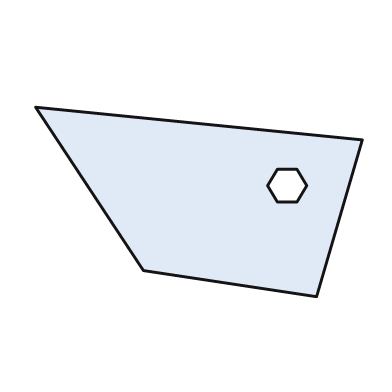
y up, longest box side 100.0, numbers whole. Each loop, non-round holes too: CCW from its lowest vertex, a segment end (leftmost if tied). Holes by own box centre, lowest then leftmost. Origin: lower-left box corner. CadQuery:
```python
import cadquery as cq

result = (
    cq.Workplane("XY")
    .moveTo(86.0, 0.0)
    .lineTo(100.0, 48.0)
    .lineTo(0.0, 58.0)
    .lineTo(33.0, 8.0)
    .close()
    .moveTo(74.0, 29.0)
    .lineTo(80.0, 29.0)
    .lineTo(83.0, 34.0)
    .lineTo(80.0, 39.0)
    .lineTo(74.0, 39.0)
    .lineTo(71.0, 34.0)
    .close()
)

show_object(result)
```